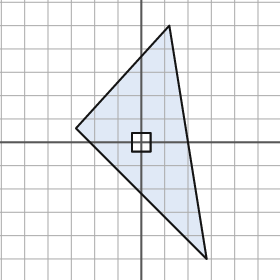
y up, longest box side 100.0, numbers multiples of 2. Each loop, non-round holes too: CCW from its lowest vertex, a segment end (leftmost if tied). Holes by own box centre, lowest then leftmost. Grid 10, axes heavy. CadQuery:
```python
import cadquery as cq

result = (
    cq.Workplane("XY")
    .moveTo(28.0, -50.0)
    .lineTo(12.0, 50.0)
    .lineTo(-28.0, 6.0)
    .close()
    .moveTo(-4.0, -4.0)
    .lineTo(4.0, -4.0)
    .lineTo(4.0, 4.0)
    .lineTo(-4.0, 4.0)
    .close()
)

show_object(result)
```